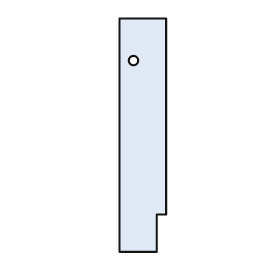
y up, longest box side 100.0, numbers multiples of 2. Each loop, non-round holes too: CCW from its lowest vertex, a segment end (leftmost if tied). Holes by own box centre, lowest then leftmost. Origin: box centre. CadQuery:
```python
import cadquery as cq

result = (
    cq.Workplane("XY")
    .moveTo(-10.0, -50.0)
    .lineTo(6.0, -50.0)
    .lineTo(6.0, -34.0)
    .lineTo(10.0, -34.0)
    .lineTo(10.0, 50.0)
    .lineTo(-10.0, 50.0)
    .close()
    .moveTo(-4.0, 32.0)
    .circle(2.0)
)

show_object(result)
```